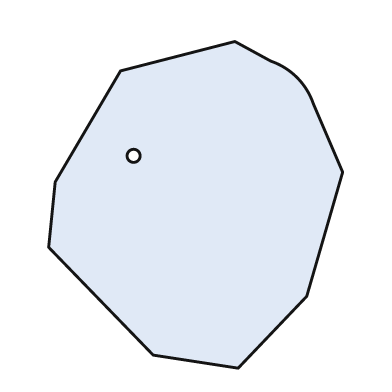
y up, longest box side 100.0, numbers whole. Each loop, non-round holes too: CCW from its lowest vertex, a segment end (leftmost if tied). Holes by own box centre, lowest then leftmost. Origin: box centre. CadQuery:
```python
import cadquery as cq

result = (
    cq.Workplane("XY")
    .moveTo(13.0, -50.0)
    .lineTo(34.0, -28.0)
    .lineTo(45.0, 10.0)
    .lineTo(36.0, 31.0)
    .threePointArc((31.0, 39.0), (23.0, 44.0))
    .lineTo(12.0, 50.0)
    .lineTo(-23.0, 41.0)
    .lineTo(-43.0, 7.0)
    .lineTo(-45.0, -13.0)
    .lineTo(-13.0, -46.0)
    .close()
    .moveTo(-19.0, 15.0)
    .circle(2.0)
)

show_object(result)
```